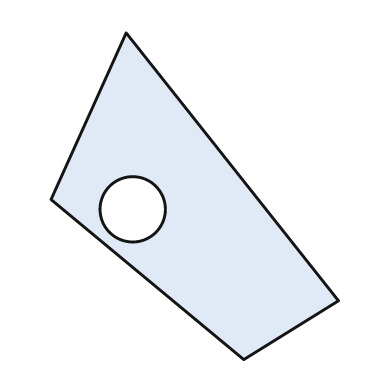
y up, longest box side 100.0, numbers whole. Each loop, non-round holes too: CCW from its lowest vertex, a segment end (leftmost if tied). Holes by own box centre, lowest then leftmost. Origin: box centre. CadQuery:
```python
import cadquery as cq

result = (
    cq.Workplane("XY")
    .moveTo(15.0, -50.0)
    .lineTo(44.0, -32.0)
    .lineTo(-21.0, 50.0)
    .lineTo(-44.0, -1.0)
    .close()
    .moveTo(-19.0, -4.0)
    .circle(10.0)
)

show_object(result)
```